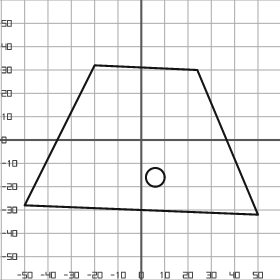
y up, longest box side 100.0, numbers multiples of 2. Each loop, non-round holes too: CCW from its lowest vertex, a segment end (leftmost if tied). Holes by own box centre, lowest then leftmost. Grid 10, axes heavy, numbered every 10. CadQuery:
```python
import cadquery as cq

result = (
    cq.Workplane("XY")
    .moveTo(50.0, -32.0)
    .lineTo(24.0, 30.0)
    .lineTo(-20.0, 32.0)
    .lineTo(-50.0, -28.0)
    .close()
    .moveTo(6.0, -16.0)
    .circle(4.0)
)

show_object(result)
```